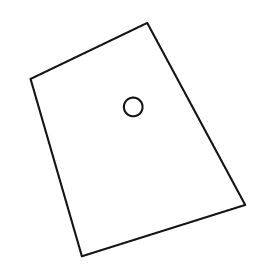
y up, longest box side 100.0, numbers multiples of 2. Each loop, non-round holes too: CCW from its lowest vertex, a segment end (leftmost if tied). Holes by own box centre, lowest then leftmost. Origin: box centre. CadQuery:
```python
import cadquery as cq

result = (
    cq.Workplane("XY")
    .moveTo(-24.0, -50.0)
    .lineTo(46.0, -28.0)
    .lineTo(4.0, 50.0)
    .lineTo(-46.0, 26.0)
    .close()
    .moveTo(-2.0, 14.0)
    .circle(4.0)
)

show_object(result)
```